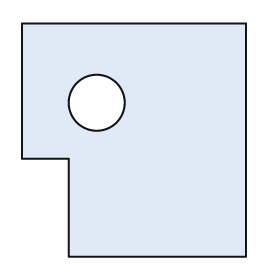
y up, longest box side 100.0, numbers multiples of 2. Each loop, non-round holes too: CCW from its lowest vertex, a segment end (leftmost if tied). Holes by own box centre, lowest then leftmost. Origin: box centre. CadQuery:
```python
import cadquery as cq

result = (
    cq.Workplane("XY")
    .moveTo(-28.0, -50.0)
    .lineTo(48.0, -50.0)
    .lineTo(48.0, 50.0)
    .lineTo(-48.0, 50.0)
    .lineTo(-48.0, -8.0)
    .lineTo(-28.0, -8.0)
    .close()
    .moveTo(-16.0, 16.0)
    .circle(12.0)
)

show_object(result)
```